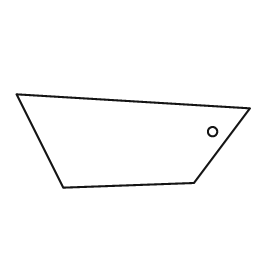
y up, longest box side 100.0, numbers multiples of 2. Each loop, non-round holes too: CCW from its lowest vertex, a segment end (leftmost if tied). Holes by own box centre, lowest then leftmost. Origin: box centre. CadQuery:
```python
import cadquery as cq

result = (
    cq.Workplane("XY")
    .moveTo(-30.0, -20.0)
    .lineTo(26.0, -18.0)
    .lineTo(50.0, 14.0)
    .lineTo(-50.0, 20.0)
    .close()
    .moveTo(34.0, 4.0)
    .circle(2.0)
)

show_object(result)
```